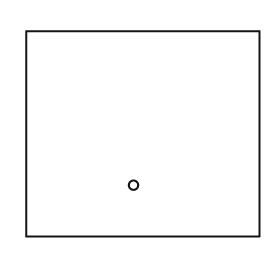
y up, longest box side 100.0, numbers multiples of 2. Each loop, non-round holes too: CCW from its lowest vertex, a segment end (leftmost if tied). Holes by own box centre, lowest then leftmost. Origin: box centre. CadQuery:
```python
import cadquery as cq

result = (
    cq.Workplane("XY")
    .moveTo(-50.0, -44.0)
    .lineTo(50.0, -44.0)
    .lineTo(50.0, 44.0)
    .lineTo(-50.0, 44.0)
    .close()
    .moveTo(-4.0, -22.0)
    .circle(2.0)
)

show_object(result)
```